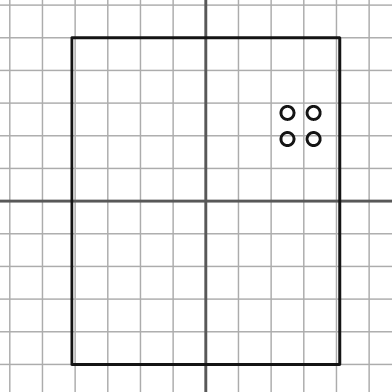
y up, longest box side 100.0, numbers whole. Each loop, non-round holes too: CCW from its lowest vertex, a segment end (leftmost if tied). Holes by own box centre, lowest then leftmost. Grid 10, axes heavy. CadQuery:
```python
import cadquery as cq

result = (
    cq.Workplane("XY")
    .moveTo(-41.0, -50.0)
    .lineTo(41.0, -50.0)
    .lineTo(41.0, 50.0)
    .lineTo(-41.0, 50.0)
    .close()
    .moveTo(25.0, 19.0)
    .circle(2.0)
    .moveTo(33.0, 19.0)
    .circle(2.0)
    .moveTo(25.0, 27.0)
    .circle(2.0)
    .moveTo(33.0, 27.0)
    .circle(2.0)
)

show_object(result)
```